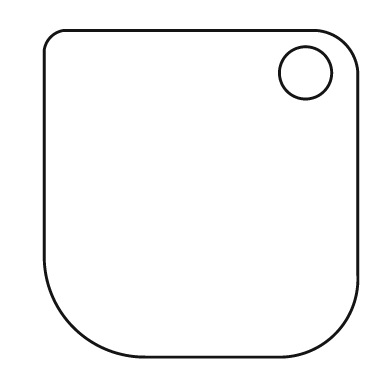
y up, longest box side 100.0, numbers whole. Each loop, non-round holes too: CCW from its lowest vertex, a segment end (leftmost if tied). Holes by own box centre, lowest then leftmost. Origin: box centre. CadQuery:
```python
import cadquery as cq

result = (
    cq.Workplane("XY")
    .moveTo(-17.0, -50.0)
    .lineTo(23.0, -50.0)
    .threePointArc((41.0, -43.0), (48.0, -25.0))
    .lineTo(48.0, 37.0)
    .threePointArc((44.0, 46.0), (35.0, 50.0))
    .lineTo(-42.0, 50.0)
    .threePointArc((-46.0, 48.0), (-48.0, 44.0))
    .lineTo(-48.0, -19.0)
    .threePointArc((-39.0, -41.0), (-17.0, -50.0))
    .close()
    .moveTo(32.0, 37.0)
    .circle(8.0)
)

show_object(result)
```